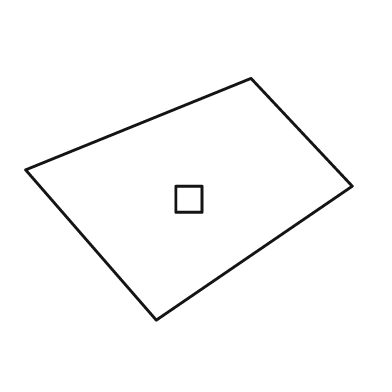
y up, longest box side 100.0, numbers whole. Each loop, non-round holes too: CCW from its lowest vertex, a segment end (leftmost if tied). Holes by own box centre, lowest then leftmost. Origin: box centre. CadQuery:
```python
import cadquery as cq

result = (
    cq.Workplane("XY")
    .moveTo(-10.0, -37.0)
    .lineTo(50.0, 4.0)
    .lineTo(19.0, 37.0)
    .lineTo(-50.0, 9.0)
    .close()
    .moveTo(-4.0, -4.0)
    .lineTo(4.0, -4.0)
    .lineTo(4.0, 4.0)
    .lineTo(-4.0, 4.0)
    .close()
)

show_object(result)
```